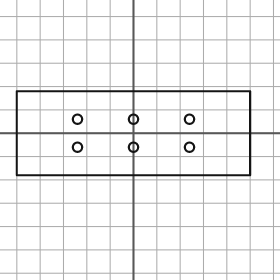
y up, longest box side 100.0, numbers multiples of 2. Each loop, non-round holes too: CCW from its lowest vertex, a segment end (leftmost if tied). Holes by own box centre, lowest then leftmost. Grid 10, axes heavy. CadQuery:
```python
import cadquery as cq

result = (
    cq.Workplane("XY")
    .moveTo(-50.0, -18.0)
    .lineTo(50.0, -18.0)
    .lineTo(50.0, 18.0)
    .lineTo(-50.0, 18.0)
    .close()
    .moveTo(-24.0, -6.0)
    .circle(2.0)
    .moveTo(0.0, -6.0)
    .circle(2.0)
    .moveTo(24.0, -6.0)
    .circle(2.0)
    .moveTo(-24.0, 6.0)
    .circle(2.0)
    .moveTo(0.0, 6.0)
    .circle(2.0)
    .moveTo(24.0, 6.0)
    .circle(2.0)
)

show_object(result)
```